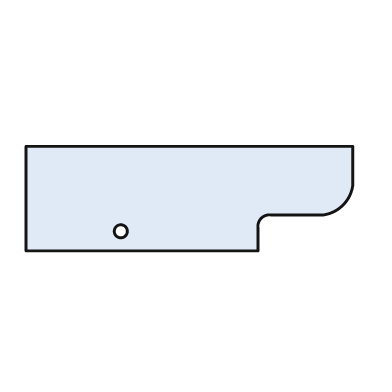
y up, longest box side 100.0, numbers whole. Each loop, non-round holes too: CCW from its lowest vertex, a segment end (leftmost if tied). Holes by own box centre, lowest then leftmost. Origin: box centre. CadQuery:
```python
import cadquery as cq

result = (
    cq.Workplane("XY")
    .moveTo(-50.0, -16.0)
    .lineTo(21.0, -16.0)
    .lineTo(21.0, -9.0)
    .threePointArc((22.0, -6.0), (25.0, -5.0))
    .lineTo(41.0, -5.0)
    .threePointArc((47.0, -2.0), (50.0, 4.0))
    .lineTo(50.0, 16.0)
    .lineTo(-50.0, 16.0)
    .close()
    .moveTo(-21.0, -10.0)
    .circle(2.0)
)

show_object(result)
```